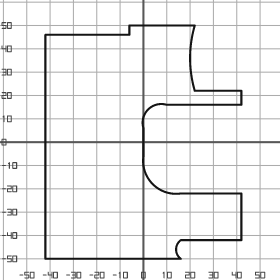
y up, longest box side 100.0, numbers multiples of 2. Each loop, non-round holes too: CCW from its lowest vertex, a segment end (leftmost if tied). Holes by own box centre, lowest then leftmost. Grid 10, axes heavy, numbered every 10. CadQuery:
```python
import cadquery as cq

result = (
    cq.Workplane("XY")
    .moveTo(-42.0, -50.0)
    .lineTo(16.0, -50.0)
    .threePointArc((14.0, -46.0), (16.0, -42.0))
    .lineTo(42.0, -42.0)
    .lineTo(42.0, -22.0)
    .lineTo(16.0, -22.0)
    .threePointArc((4.0, -18.0), (0.0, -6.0))
    .lineTo(0.0, 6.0)
    .threePointArc((2.0, 14.0), (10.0, 16.0))
    .lineTo(42.0, 16.0)
    .lineTo(42.0, 22.0)
    .lineTo(22.0, 22.0)
    .threePointArc((20.0, 36.0), (22.0, 50.0))
    .lineTo(-6.0, 50.0)
    .lineTo(-6.0, 46.0)
    .lineTo(-42.0, 46.0)
    .close()
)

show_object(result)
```